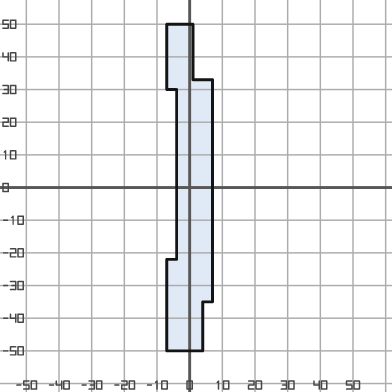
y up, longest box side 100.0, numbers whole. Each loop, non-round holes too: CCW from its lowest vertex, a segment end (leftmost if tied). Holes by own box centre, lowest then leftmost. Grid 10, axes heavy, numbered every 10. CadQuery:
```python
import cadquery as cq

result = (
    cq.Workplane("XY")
    .moveTo(-7.0, -50.0)
    .lineTo(4.0, -50.0)
    .lineTo(4.0, -35.0)
    .lineTo(7.0, -35.0)
    .lineTo(7.0, 33.0)
    .lineTo(1.0, 33.0)
    .lineTo(1.0, 50.0)
    .lineTo(-7.0, 50.0)
    .lineTo(-7.0, 30.0)
    .lineTo(-4.0, 30.0)
    .lineTo(-4.0, -22.0)
    .lineTo(-7.0, -22.0)
    .close()
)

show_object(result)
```